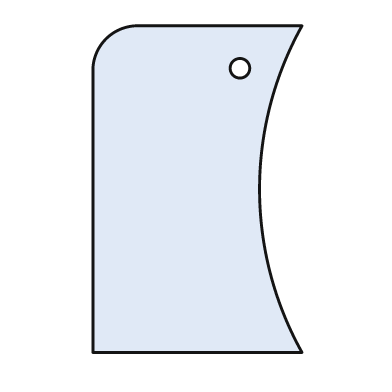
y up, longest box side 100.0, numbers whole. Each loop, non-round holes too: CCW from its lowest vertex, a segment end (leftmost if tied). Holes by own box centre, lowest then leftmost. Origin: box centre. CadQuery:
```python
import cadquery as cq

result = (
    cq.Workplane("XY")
    .moveTo(-32.0, -50.0)
    .lineTo(32.0, -50.0)
    .threePointArc((19.0, 0.0), (32.0, 50.0))
    .lineTo(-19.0, 50.0)
    .threePointArc((-28.0, 46.0), (-32.0, 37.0))
    .close()
    .moveTo(13.0, 37.0)
    .circle(3.0)
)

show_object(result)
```